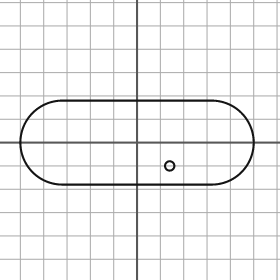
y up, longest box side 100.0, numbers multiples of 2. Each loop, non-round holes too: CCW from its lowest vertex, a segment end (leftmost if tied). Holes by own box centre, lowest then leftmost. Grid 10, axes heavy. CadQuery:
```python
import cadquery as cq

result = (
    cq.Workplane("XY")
    .moveTo(-32.0, -18.0)
    .lineTo(32.0, -18.0)
    .threePointArc((50.0, 0.0), (32.0, 18.0))
    .lineTo(-32.0, 18.0)
    .threePointArc((-50.0, 0.0), (-32.0, -18.0))
    .close()
    .moveTo(14.0, -10.0)
    .circle(2.0)
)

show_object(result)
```